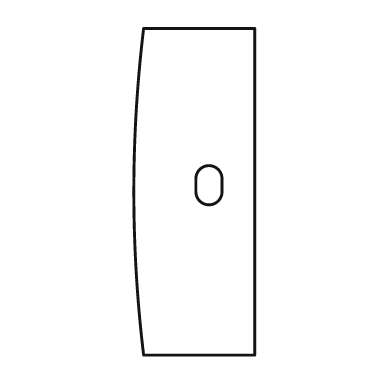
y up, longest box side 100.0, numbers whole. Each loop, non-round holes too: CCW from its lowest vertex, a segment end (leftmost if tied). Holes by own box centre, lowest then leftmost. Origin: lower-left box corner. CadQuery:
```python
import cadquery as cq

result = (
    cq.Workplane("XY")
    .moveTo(3.0, 0.0)
    .lineTo(37.0, 0.0)
    .lineTo(37.0, 100.0)
    .lineTo(3.0, 100.0)
    .threePointArc((0.0, 50.0), (3.0, 0.0))
    .close()
    .moveTo(19.0, 50.0)
    .threePointArc((23.0, 46.0), (27.0, 50.0))
    .lineTo(27.0, 54.0)
    .threePointArc((23.0, 58.0), (19.0, 54.0))
    .close()
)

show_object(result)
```